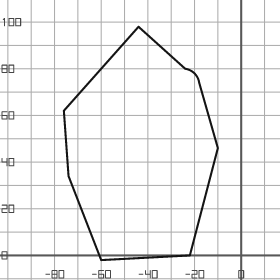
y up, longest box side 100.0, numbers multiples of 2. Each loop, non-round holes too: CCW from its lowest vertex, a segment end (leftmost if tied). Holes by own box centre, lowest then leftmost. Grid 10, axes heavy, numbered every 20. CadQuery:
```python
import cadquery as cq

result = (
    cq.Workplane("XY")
    .moveTo(-60.0, -2.0)
    .lineTo(-22.0, 0.0)
    .lineTo(-10.0, 46.0)
    .lineTo(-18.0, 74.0)
    .threePointArc((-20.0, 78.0), (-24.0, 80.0))
    .lineTo(-44.0, 98.0)
    .lineTo(-76.0, 62.0)
    .lineTo(-74.0, 34.0)
    .close()
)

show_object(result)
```